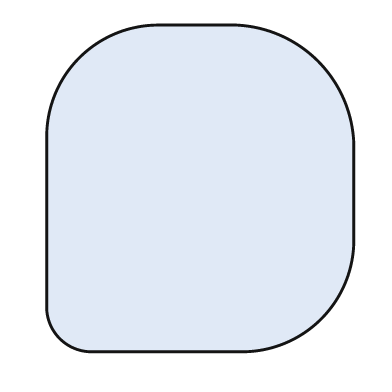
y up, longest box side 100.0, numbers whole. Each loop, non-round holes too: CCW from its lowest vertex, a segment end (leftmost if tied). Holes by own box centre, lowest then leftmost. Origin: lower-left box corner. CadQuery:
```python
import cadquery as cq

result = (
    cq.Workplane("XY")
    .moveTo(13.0, 0.0)
    .lineTo(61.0, 0.0)
    .threePointArc((84.0, 10.0), (94.0, 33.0))
    .lineTo(94.0, 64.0)
    .threePointArc((83.0, 89.0), (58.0, 100.0))
    .lineTo(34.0, 100.0)
    .threePointArc((10.0, 90.0), (0.0, 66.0))
    .lineTo(0.0, 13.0)
    .threePointArc((4.0, 4.0), (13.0, 0.0))
    .close()
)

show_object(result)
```